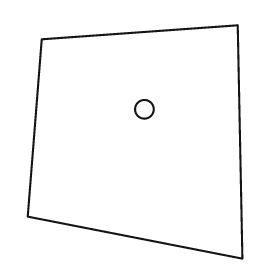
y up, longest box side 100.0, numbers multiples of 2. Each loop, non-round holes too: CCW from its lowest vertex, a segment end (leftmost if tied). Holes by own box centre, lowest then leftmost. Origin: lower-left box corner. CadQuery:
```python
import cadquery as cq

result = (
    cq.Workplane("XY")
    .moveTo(92.0, 0.0)
    .lineTo(90.0, 100.0)
    .lineTo(6.0, 94.0)
    .lineTo(0.0, 18.0)
    .close()
    .moveTo(50.0, 64.0)
    .circle(4.0)
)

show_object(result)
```